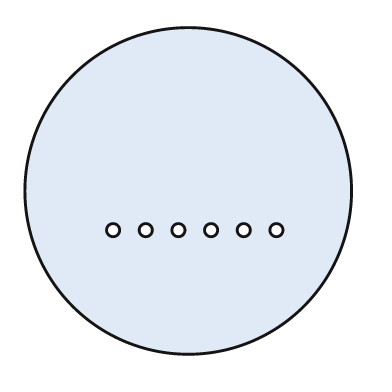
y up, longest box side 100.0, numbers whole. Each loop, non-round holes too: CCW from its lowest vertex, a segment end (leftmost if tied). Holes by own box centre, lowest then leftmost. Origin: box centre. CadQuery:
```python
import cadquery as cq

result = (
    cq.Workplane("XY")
    .moveTo(0.0, 0.0)
    .circle(50.0)
    .moveTo(-23.0, -12.0)
    .circle(2.0)
    .moveTo(-13.0, -12.0)
    .circle(2.0)
    .moveTo(-3.0, -12.0)
    .circle(2.0)
    .moveTo(7.0, -12.0)
    .circle(2.0)
    .moveTo(17.0, -12.0)
    .circle(2.0)
    .moveTo(27.0, -12.0)
    .circle(2.0)
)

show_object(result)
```